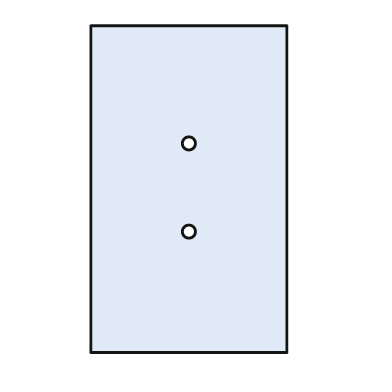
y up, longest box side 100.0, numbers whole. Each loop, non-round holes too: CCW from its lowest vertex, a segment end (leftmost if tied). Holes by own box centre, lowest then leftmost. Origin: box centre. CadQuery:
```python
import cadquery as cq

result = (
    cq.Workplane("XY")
    .moveTo(-30.0, -50.0)
    .lineTo(30.0, -50.0)
    .lineTo(30.0, 50.0)
    .lineTo(-30.0, 50.0)
    .close()
    .moveTo(0.0, -13.0)
    .circle(2.0)
    .moveTo(0.0, 14.0)
    .circle(2.0)
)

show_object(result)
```